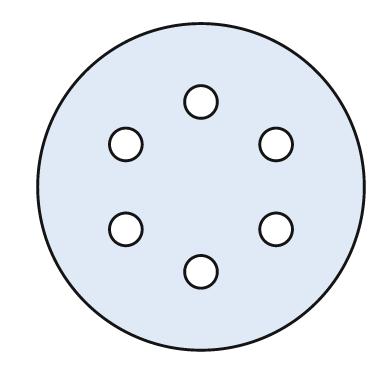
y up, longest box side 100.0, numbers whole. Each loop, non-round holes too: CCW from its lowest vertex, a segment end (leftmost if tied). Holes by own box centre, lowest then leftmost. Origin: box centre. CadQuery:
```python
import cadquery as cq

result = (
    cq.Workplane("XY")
    .moveTo(0.0, 0.0)
    .circle(50.0)
    .moveTo(0.0, -26.0)
    .circle(5.0)
    .moveTo(-23.0, -13.0)
    .circle(5.0)
    .moveTo(23.0, -13.0)
    .circle(5.0)
    .moveTo(-23.0, 13.0)
    .circle(5.0)
    .moveTo(23.0, 13.0)
    .circle(5.0)
    .moveTo(0.0, 26.0)
    .circle(5.0)
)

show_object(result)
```